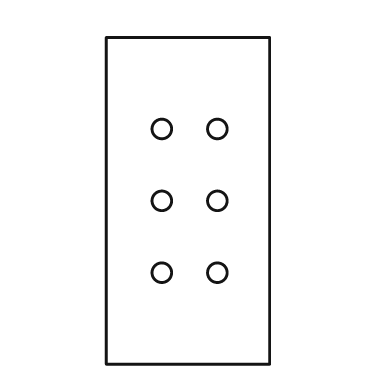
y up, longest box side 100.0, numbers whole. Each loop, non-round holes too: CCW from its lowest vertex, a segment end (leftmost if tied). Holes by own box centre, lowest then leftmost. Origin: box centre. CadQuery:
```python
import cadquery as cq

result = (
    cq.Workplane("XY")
    .moveTo(-25.0, -50.0)
    .lineTo(25.0, -50.0)
    .lineTo(25.0, 50.0)
    .lineTo(-25.0, 50.0)
    .close()
    .moveTo(-8.0, -22.0)
    .circle(3.0)
    .moveTo(9.0, -22.0)
    .circle(3.0)
    .moveTo(-8.0, 0.0)
    .circle(3.0)
    .moveTo(9.0, 0.0)
    .circle(3.0)
    .moveTo(-8.0, 22.0)
    .circle(3.0)
    .moveTo(9.0, 22.0)
    .circle(3.0)
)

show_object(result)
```